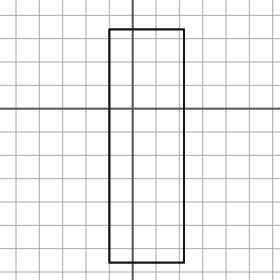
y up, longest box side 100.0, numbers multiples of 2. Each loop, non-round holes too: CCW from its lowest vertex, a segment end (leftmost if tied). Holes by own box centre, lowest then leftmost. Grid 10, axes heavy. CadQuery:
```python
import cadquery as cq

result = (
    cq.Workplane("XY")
    .moveTo(-10.0, -66.0)
    .lineTo(22.0, -66.0)
    .lineTo(22.0, 34.0)
    .lineTo(-10.0, 34.0)
    .close()
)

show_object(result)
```